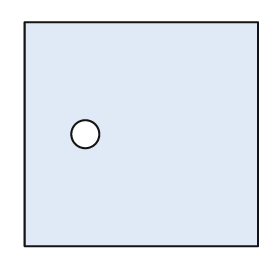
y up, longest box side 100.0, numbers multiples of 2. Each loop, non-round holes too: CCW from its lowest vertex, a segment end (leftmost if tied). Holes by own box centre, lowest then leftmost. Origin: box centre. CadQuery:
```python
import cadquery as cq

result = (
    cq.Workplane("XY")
    .moveTo(-50.0, -48.0)
    .lineTo(50.0, -48.0)
    .lineTo(50.0, 48.0)
    .lineTo(-50.0, 48.0)
    .close()
    .moveTo(-24.0, 0.0)
    .circle(6.0)
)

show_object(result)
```